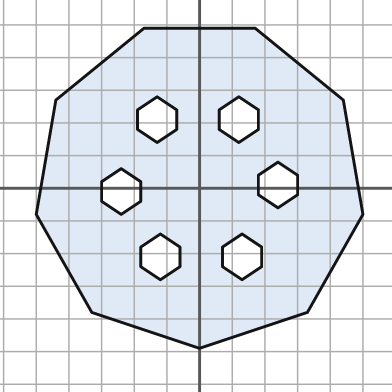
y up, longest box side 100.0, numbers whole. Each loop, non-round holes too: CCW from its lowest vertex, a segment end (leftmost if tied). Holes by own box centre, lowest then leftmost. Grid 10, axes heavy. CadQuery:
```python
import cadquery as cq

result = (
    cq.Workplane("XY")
    .moveTo(0.0, -49.0)
    .lineTo(33.0, -38.0)
    .lineTo(50.0, -8.0)
    .lineTo(44.0, 27.0)
    .lineTo(17.0, 49.0)
    .lineTo(-17.0, 49.0)
    .lineTo(-44.0, 27.0)
    .lineTo(-50.0, -8.0)
    .lineTo(-33.0, -38.0)
    .close()
    .moveTo(-12.0, -28.0)
    .lineTo(-6.0, -24.0)
    .lineTo(-6.0, -18.0)
    .lineTo(-12.0, -14.0)
    .lineTo(-18.0, -18.0)
    .lineTo(-18.0, -24.0)
    .close()
    .moveTo(13.0, -28.0)
    .lineTo(19.0, -24.0)
    .lineTo(19.0, -18.0)
    .lineTo(13.0, -14.0)
    .lineTo(7.0, -18.0)
    .lineTo(7.0, -24.0)
    .close()
    .moveTo(-24.0, -8.0)
    .lineTo(-18.0, -4.0)
    .lineTo(-18.0, 2.0)
    .lineTo(-24.0, 6.0)
    .lineTo(-30.0, 2.0)
    .lineTo(-30.0, -4.0)
    .close()
    .moveTo(24.0, -6.0)
    .lineTo(30.0, -2.0)
    .lineTo(30.0, 4.0)
    .lineTo(24.0, 8.0)
    .lineTo(18.0, 4.0)
    .lineTo(18.0, -2.0)
    .close()
    .moveTo(-13.0, 14.0)
    .lineTo(-7.0, 18.0)
    .lineTo(-7.0, 24.0)
    .lineTo(-13.0, 28.0)
    .lineTo(-19.0, 24.0)
    .lineTo(-19.0, 18.0)
    .close()
    .moveTo(12.0, 14.0)
    .lineTo(18.0, 18.0)
    .lineTo(18.0, 24.0)
    .lineTo(12.0, 28.0)
    .lineTo(6.0, 24.0)
    .lineTo(6.0, 18.0)
    .close()
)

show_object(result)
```